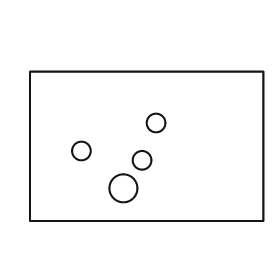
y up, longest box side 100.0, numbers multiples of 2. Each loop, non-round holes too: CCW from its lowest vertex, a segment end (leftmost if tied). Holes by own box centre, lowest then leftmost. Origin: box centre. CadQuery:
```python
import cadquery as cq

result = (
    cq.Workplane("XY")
    .moveTo(-50.0, -32.0)
    .lineTo(50.0, -32.0)
    .lineTo(50.0, 32.0)
    .lineTo(-50.0, 32.0)
    .close()
    .moveTo(-10.0, -18.0)
    .circle(6.0)
    .moveTo(-2.0, -6.0)
    .circle(4.0)
    .moveTo(-28.0, -2.0)
    .circle(4.0)
    .moveTo(4.0, 10.0)
    .circle(4.0)
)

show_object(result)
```